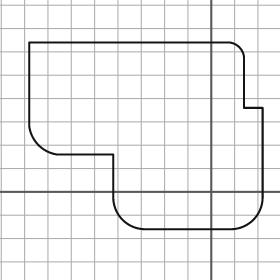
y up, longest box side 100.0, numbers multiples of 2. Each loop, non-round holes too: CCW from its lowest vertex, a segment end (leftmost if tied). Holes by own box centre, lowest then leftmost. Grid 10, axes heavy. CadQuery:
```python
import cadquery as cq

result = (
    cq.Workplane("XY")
    .moveTo(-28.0, -16.0)
    .lineTo(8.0, -16.0)
    .threePointArc((18.0, -12.0), (22.0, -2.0))
    .lineTo(22.0, 36.0)
    .lineTo(14.0, 36.0)
    .lineTo(14.0, 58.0)
    .threePointArc((12.0, 62.0), (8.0, 64.0))
    .lineTo(-78.0, 64.0)
    .lineTo(-78.0, 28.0)
    .threePointArc((-74.0, 20.0), (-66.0, 16.0))
    .lineTo(-42.0, 16.0)
    .lineTo(-42.0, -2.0)
    .threePointArc((-38.0, -12.0), (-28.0, -16.0))
    .close()
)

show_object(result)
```